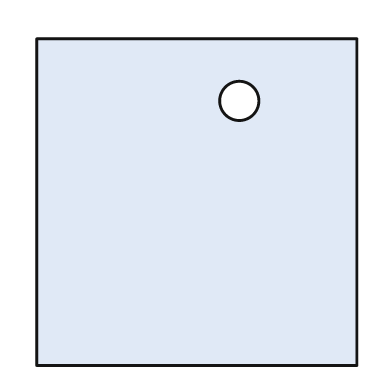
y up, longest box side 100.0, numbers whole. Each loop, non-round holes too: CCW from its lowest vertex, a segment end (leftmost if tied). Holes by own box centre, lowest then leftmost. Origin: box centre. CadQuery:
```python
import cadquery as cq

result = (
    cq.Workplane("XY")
    .moveTo(-49.0, -50.0)
    .lineTo(49.0, -50.0)
    .lineTo(49.0, 50.0)
    .lineTo(-49.0, 50.0)
    .close()
    .moveTo(13.0, 31.0)
    .circle(6.0)
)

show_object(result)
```